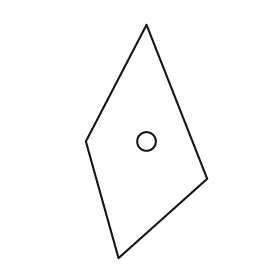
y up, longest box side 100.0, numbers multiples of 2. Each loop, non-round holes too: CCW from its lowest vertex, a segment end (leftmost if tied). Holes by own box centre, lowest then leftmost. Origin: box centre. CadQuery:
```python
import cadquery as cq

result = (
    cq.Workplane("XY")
    .moveTo(-12.0, -50.0)
    .lineTo(26.0, -16.0)
    .lineTo(0.0, 50.0)
    .lineTo(-26.0, 0.0)
    .close()
    .moveTo(0.0, 0.0)
    .circle(4.0)
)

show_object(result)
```